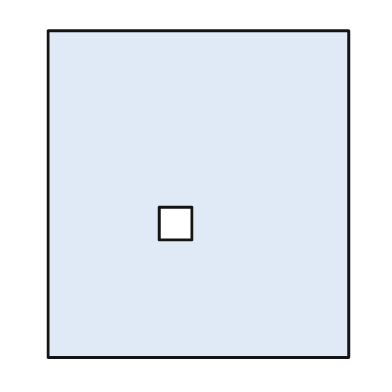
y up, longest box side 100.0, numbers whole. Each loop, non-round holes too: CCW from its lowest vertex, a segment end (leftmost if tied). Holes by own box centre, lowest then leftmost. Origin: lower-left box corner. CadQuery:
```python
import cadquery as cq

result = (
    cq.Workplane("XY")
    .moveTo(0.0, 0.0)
    .lineTo(92.0, 0.0)
    .lineTo(92.0, 100.0)
    .lineTo(0.0, 100.0)
    .close()
    .moveTo(34.0, 36.0)
    .lineTo(44.0, 36.0)
    .lineTo(44.0, 46.0)
    .lineTo(34.0, 46.0)
    .close()
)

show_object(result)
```